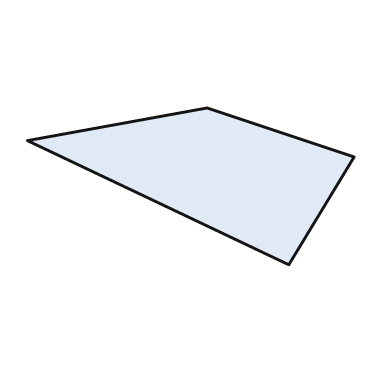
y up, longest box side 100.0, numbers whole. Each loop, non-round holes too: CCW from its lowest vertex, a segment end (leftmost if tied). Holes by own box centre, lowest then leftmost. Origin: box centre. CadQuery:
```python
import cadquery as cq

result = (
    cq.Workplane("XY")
    .moveTo(30.0, -24.0)
    .lineTo(50.0, 9.0)
    .lineTo(5.0, 24.0)
    .lineTo(-50.0, 14.0)
    .close()
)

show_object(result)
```